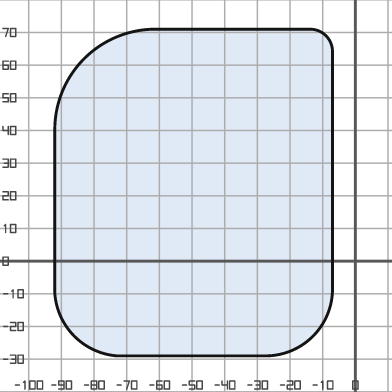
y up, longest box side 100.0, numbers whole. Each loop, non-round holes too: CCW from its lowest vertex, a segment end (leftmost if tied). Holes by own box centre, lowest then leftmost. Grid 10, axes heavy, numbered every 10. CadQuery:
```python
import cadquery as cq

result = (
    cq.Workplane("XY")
    .moveTo(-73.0, -29.0)
    .lineTo(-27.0, -29.0)
    .threePointArc((-13.0, -23.0), (-7.0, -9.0))
    .lineTo(-7.0, 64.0)
    .threePointArc((-9.0, 69.0), (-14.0, 71.0))
    .lineTo(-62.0, 71.0)
    .threePointArc((-83.0, 62.0), (-92.0, 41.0))
    .lineTo(-92.0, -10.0)
    .threePointArc((-86.0, -23.0), (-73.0, -29.0))
    .close()
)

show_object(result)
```